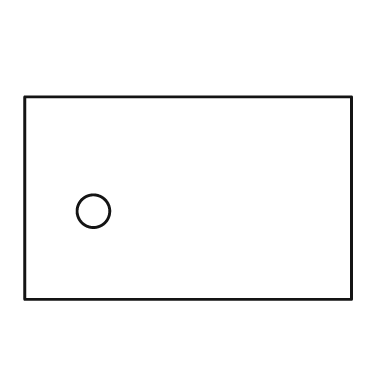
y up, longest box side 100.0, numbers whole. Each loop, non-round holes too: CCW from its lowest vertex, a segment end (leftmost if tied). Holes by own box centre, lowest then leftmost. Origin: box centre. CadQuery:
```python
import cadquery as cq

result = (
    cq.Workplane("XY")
    .moveTo(-50.0, -31.0)
    .lineTo(50.0, -31.0)
    .lineTo(50.0, 31.0)
    .lineTo(-50.0, 31.0)
    .close()
    .moveTo(-29.0, -4.0)
    .circle(5.0)
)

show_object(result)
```